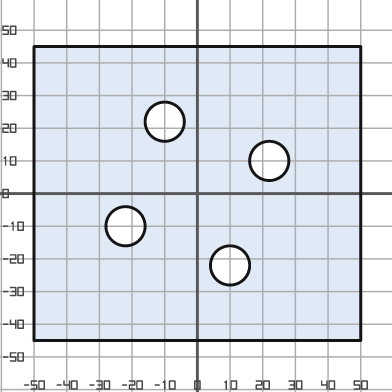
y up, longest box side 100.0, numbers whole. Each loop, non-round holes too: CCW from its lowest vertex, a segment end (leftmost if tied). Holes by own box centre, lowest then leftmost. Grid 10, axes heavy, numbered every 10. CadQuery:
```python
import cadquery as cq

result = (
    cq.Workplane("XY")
    .moveTo(-50.0, -45.0)
    .lineTo(50.0, -45.0)
    .lineTo(50.0, 45.0)
    .lineTo(-50.0, 45.0)
    .close()
    .moveTo(10.0, -22.0)
    .circle(6.0)
    .moveTo(-22.0, -10.0)
    .circle(6.0)
    .moveTo(22.0, 10.0)
    .circle(6.0)
    .moveTo(-10.0, 22.0)
    .circle(6.0)
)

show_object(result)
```